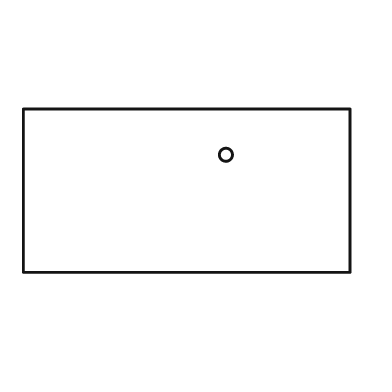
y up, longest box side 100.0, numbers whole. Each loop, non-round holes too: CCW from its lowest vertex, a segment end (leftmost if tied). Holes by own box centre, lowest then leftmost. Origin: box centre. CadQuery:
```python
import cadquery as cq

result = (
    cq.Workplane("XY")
    .moveTo(-50.0, -25.0)
    .lineTo(50.0, -25.0)
    .lineTo(50.0, 25.0)
    .lineTo(-50.0, 25.0)
    .close()
    .moveTo(12.0, 11.0)
    .circle(2.0)
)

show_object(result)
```